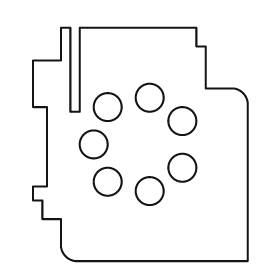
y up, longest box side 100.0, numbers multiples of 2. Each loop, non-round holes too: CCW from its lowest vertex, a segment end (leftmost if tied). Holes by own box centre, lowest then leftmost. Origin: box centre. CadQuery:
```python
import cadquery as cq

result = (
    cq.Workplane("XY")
    .moveTo(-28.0, -50.0)
    .lineTo(46.0, -50.0)
    .lineTo(46.0, 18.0)
    .threePointArc((44.0, 22.0), (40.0, 24.0))
    .lineTo(28.0, 24.0)
    .lineTo(28.0, 42.0)
    .lineTo(24.0, 42.0)
    .lineTo(24.0, 50.0)
    .lineTo(-26.0, 50.0)
    .lineTo(-26.0, 14.0)
    .lineTo(-30.0, 14.0)
    .lineTo(-30.0, 50.0)
    .lineTo(-34.0, 50.0)
    .lineTo(-34.0, 36.0)
    .lineTo(-46.0, 36.0)
    .lineTo(-46.0, 16.0)
    .lineTo(-40.0, 16.0)
    .lineTo(-40.0, -18.0)
    .lineTo(-46.0, -18.0)
    .lineTo(-46.0, -24.0)
    .lineTo(-42.0, -24.0)
    .lineTo(-42.0, -32.0)
    .lineTo(-34.0, -32.0)
    .lineTo(-34.0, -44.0)
    .threePointArc((-32.0, -48.0), (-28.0, -50.0))
    .close()
    .moveTo(4.0, -20.0)
    .circle(6.0)
    .moveTo(-14.0, -16.0)
    .circle(6.0)
    .moveTo(18.0, -10.0)
    .circle(6.0)
    .moveTo(-20.0, 0.0)
    .circle(6.0)
    .moveTo(18.0, 10.0)
    .circle(6.0)
    .moveTo(-14.0, 16.0)
    .circle(6.0)
    .moveTo(4.0, 20.0)
    .circle(6.0)
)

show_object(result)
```